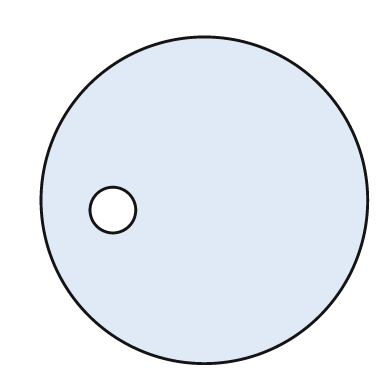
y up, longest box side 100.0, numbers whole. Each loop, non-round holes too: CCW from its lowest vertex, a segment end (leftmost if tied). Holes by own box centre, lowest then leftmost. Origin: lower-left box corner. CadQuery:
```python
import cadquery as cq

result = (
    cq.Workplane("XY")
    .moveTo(50.0, 50.0)
    .circle(50.0)
    .moveTo(22.0, 47.0)
    .circle(7.0)
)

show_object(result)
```